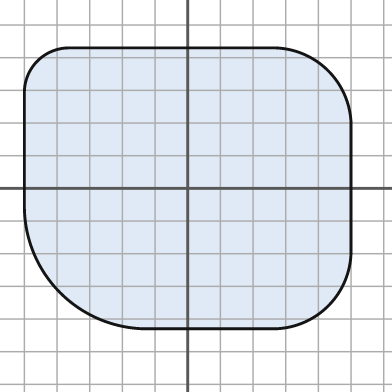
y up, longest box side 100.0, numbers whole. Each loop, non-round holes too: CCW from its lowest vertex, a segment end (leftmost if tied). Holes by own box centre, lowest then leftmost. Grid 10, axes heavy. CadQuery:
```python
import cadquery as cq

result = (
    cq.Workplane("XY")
    .moveTo(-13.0, -43.0)
    .lineTo(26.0, -43.0)
    .threePointArc((43.0, -36.0), (50.0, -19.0))
    .lineTo(50.0, 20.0)
    .threePointArc((43.0, 36.0), (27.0, 43.0))
    .lineTo(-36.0, 43.0)
    .threePointArc((-46.0, 39.0), (-50.0, 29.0))
    .lineTo(-50.0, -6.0)
    .threePointArc((-39.0, -32.0), (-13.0, -43.0))
    .close()
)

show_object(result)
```